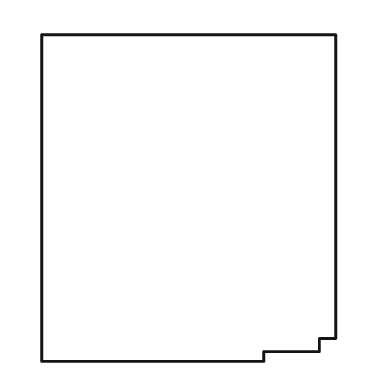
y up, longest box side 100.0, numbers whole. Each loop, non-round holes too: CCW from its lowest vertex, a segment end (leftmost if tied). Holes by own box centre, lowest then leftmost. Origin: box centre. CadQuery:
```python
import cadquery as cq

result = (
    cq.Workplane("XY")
    .moveTo(-45.0, -50.0)
    .lineTo(23.0, -50.0)
    .lineTo(23.0, -47.0)
    .lineTo(40.0, -47.0)
    .lineTo(40.0, -43.0)
    .lineTo(45.0, -43.0)
    .lineTo(45.0, 50.0)
    .lineTo(-45.0, 50.0)
    .close()
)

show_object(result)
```